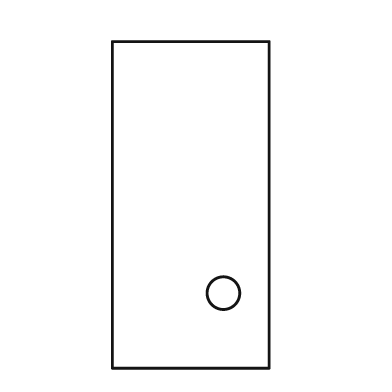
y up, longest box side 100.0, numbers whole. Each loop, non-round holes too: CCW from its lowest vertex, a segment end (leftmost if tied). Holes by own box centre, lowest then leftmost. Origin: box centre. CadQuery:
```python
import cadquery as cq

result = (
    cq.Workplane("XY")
    .moveTo(-24.0, -50.0)
    .lineTo(24.0, -50.0)
    .lineTo(24.0, 50.0)
    .lineTo(-24.0, 50.0)
    .close()
    .moveTo(10.0, -27.0)
    .circle(5.0)
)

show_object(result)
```